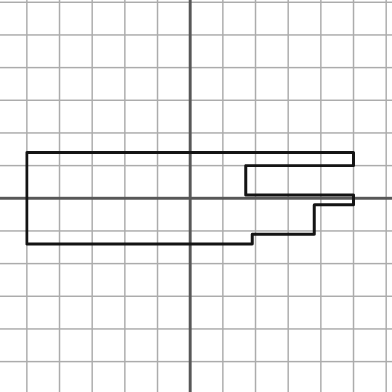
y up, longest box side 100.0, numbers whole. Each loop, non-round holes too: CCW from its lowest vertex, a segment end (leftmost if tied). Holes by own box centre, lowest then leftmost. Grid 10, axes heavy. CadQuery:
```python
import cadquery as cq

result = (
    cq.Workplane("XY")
    .moveTo(-50.0, -14.0)
    .lineTo(19.0, -14.0)
    .lineTo(19.0, -11.0)
    .lineTo(38.0, -11.0)
    .lineTo(38.0, -2.0)
    .lineTo(50.0, -2.0)
    .lineTo(50.0, 1.0)
    .lineTo(17.0, 1.0)
    .lineTo(17.0, 10.0)
    .lineTo(50.0, 10.0)
    .lineTo(50.0, 14.0)
    .lineTo(-50.0, 14.0)
    .close()
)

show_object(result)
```